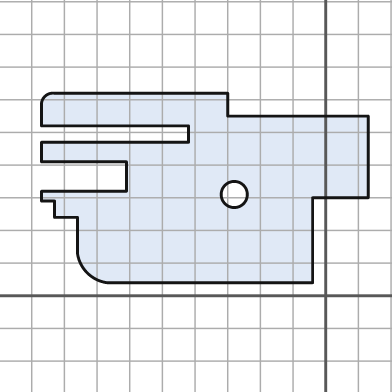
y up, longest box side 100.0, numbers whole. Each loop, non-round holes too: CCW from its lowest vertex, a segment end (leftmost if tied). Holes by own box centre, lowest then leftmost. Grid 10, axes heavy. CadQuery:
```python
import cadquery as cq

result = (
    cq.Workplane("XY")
    .moveTo(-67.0, 4.0)
    .lineTo(-4.0, 4.0)
    .lineTo(-4.0, 30.0)
    .lineTo(13.0, 30.0)
    .lineTo(13.0, 55.0)
    .lineTo(-30.0, 55.0)
    .lineTo(-30.0, 62.0)
    .lineTo(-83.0, 62.0)
    .threePointArc((-86.0, 61.0), (-87.0, 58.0))
    .lineTo(-87.0, 52.0)
    .lineTo(-42.0, 52.0)
    .lineTo(-42.0, 47.0)
    .lineTo(-87.0, 47.0)
    .lineTo(-87.0, 41.0)
    .lineTo(-61.0, 41.0)
    .lineTo(-61.0, 32.0)
    .lineTo(-87.0, 32.0)
    .lineTo(-87.0, 29.0)
    .lineTo(-83.0, 29.0)
    .lineTo(-83.0, 24.0)
    .lineTo(-76.0, 24.0)
    .lineTo(-76.0, 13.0)
    .threePointArc((-73.0, 7.0), (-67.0, 4.0))
    .close()
    .moveTo(-28.0, 31.0)
    .circle(4.0)
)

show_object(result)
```